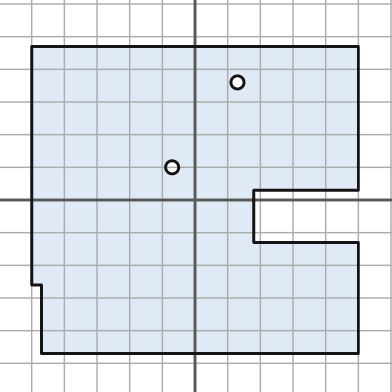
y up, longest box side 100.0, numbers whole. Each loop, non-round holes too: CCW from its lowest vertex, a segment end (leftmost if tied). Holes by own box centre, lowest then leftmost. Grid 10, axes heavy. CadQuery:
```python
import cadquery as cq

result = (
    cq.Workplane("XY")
    .moveTo(-47.0, -47.0)
    .lineTo(50.0, -47.0)
    .lineTo(50.0, -13.0)
    .lineTo(18.0, -13.0)
    .lineTo(18.0, 3.0)
    .lineTo(50.0, 3.0)
    .lineTo(50.0, 47.0)
    .lineTo(-50.0, 47.0)
    .lineTo(-50.0, -26.0)
    .lineTo(-47.0, -26.0)
    .close()
    .moveTo(-7.0, 10.0)
    .circle(2.0)
    .moveTo(13.0, 36.0)
    .circle(2.0)
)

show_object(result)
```